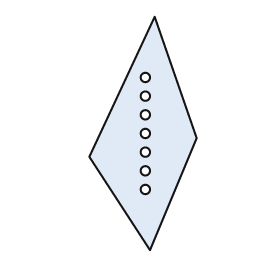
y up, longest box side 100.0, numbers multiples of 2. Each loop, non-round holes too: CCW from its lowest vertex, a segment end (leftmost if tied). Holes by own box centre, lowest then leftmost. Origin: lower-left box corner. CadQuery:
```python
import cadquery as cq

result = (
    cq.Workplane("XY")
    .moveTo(26.0, 0.0)
    .lineTo(46.0, 48.0)
    .lineTo(28.0, 100.0)
    .lineTo(0.0, 40.0)
    .close()
    .moveTo(24.0, 26.0)
    .circle(2.0)
    .moveTo(24.0, 34.0)
    .circle(2.0)
    .moveTo(24.0, 42.0)
    .circle(2.0)
    .moveTo(24.0, 50.0)
    .circle(2.0)
    .moveTo(24.0, 58.0)
    .circle(2.0)
    .moveTo(24.0, 66.0)
    .circle(2.0)
    .moveTo(24.0, 74.0)
    .circle(2.0)
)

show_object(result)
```